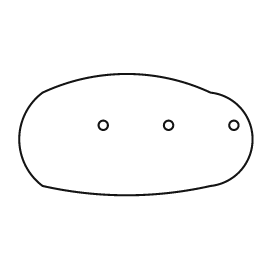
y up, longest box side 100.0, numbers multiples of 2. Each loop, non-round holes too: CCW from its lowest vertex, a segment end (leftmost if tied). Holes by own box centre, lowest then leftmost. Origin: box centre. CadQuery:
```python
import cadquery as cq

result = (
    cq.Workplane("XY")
    .moveTo(-40.0, -22.0)
    .threePointArc((-4.0, -26.0), (32.0, -22.0))
    .threePointArc((50.0, -2.0), (32.0, 18.0))
    .threePointArc((-4.0, 26.0), (-40.0, 18.0))
    .threePointArc((-50.0, -2.0), (-40.0, -22.0))
    .close()
    .moveTo(-14.0, 4.0)
    .circle(2.0)
    .moveTo(14.0, 4.0)
    .circle(2.0)
    .moveTo(42.0, 4.0)
    .circle(2.0)
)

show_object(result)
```